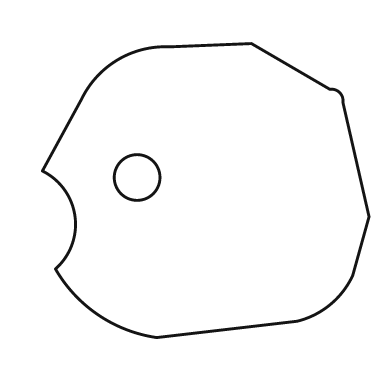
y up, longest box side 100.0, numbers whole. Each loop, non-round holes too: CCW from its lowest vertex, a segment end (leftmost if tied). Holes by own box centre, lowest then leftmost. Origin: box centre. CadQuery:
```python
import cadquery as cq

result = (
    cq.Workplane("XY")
    .moveTo(-15.0, -45.0)
    .lineTo(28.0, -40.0)
    .threePointArc((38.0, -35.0), (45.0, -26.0))
    .lineTo(50.0, -8.0)
    .lineTo(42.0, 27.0)
    .threePointArc((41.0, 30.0), (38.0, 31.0))
    .lineTo(14.0, 45.0)
    .lineTo(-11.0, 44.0)
    .threePointArc((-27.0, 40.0), (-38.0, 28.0))
    .lineTo(-50.0, 6.0)
    .threePointArc((-40.0, -8.0), (-46.0, -24.0))
    .threePointArc((-33.0, -38.0), (-15.0, -45.0))
    .close()
    .moveTo(-21.0, 4.0)
    .circle(7.0)
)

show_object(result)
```